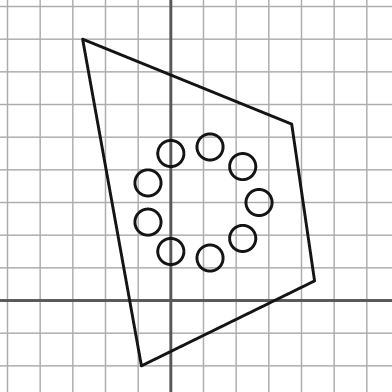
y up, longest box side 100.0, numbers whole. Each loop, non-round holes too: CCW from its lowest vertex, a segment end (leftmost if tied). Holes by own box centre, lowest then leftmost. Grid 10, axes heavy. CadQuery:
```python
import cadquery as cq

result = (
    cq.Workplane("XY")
    .moveTo(-9.0, -20.0)
    .lineTo(44.0, 6.0)
    .lineTo(37.0, 54.0)
    .lineTo(-27.0, 80.0)
    .close()
    .moveTo(12.0, 13.0)
    .circle(4.0)
    .moveTo(0.0, 15.0)
    .circle(4.0)
    .moveTo(22.0, 19.0)
    .circle(4.0)
    .moveTo(-7.0, 24.0)
    .circle(4.0)
    .moveTo(27.0, 30.0)
    .circle(4.0)
    .moveTo(-7.0, 36.0)
    .circle(4.0)
    .moveTo(22.0, 41.0)
    .circle(4.0)
    .moveTo(0.0, 45.0)
    .circle(4.0)
    .moveTo(12.0, 47.0)
    .circle(4.0)
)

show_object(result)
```